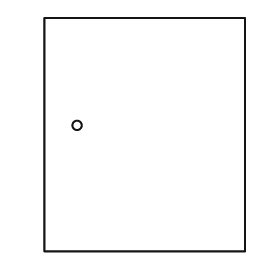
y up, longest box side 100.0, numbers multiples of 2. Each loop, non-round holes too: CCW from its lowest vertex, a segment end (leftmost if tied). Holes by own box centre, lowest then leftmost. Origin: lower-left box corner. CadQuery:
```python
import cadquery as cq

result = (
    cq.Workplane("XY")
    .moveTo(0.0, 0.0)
    .lineTo(86.0, 0.0)
    .lineTo(86.0, 100.0)
    .lineTo(0.0, 100.0)
    .close()
    .moveTo(14.0, 54.0)
    .circle(2.0)
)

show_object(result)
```